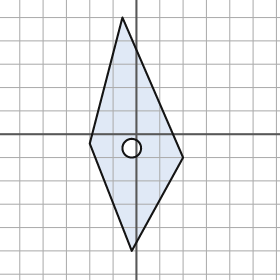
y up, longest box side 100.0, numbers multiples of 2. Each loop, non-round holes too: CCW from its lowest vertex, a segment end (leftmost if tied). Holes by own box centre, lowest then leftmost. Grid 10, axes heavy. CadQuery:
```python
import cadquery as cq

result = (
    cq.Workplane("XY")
    .moveTo(-2.0, -50.0)
    .lineTo(20.0, -10.0)
    .lineTo(-6.0, 50.0)
    .lineTo(-20.0, -4.0)
    .close()
    .moveTo(-2.0, -6.0)
    .circle(4.0)
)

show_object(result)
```